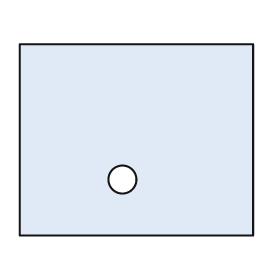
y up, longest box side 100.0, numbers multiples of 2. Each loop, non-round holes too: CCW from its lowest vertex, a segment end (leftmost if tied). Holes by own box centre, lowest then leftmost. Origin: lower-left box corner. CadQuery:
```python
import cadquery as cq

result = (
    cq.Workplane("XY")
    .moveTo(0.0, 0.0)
    .lineTo(100.0, 0.0)
    .lineTo(100.0, 82.0)
    .lineTo(0.0, 82.0)
    .close()
    .moveTo(44.0, 24.0)
    .circle(6.0)
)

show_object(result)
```